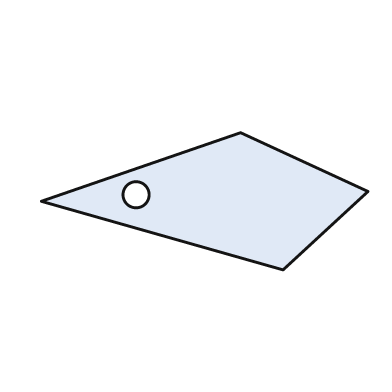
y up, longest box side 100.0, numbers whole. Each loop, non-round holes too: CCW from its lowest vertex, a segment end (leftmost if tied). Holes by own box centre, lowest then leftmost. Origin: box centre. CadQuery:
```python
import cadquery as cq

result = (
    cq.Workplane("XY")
    .moveTo(24.0, -21.0)
    .lineTo(50.0, 3.0)
    .lineTo(11.0, 21.0)
    .lineTo(-50.0, 0.0)
    .close()
    .moveTo(-21.0, 2.0)
    .circle(4.0)
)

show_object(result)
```